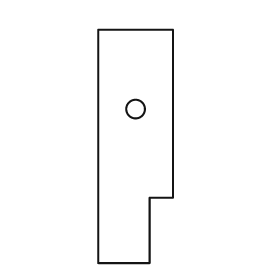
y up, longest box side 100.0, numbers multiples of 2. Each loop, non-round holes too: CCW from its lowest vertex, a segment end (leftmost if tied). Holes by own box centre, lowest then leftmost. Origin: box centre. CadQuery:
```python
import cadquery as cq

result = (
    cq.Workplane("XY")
    .moveTo(-16.0, -50.0)
    .lineTo(6.0, -50.0)
    .lineTo(6.0, -22.0)
    .lineTo(16.0, -22.0)
    .lineTo(16.0, 50.0)
    .lineTo(-16.0, 50.0)
    .close()
    .moveTo(0.0, 16.0)
    .circle(4.0)
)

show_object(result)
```